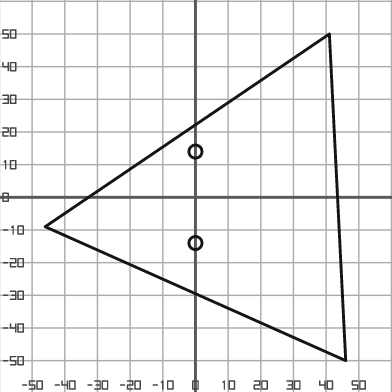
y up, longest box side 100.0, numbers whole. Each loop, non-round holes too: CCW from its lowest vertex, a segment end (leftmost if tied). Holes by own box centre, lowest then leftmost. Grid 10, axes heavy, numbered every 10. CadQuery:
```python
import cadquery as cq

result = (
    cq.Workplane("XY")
    .moveTo(46.0, -50.0)
    .lineTo(41.0, 50.0)
    .lineTo(-46.0, -9.0)
    .close()
    .moveTo(0.0, -14.0)
    .circle(2.0)
    .moveTo(0.0, 14.0)
    .circle(2.0)
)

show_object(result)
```